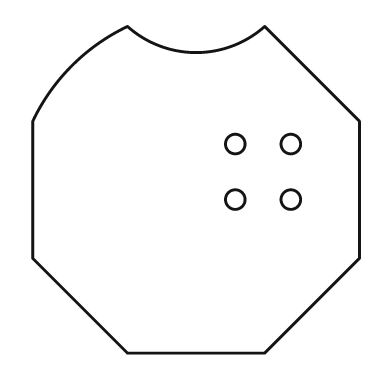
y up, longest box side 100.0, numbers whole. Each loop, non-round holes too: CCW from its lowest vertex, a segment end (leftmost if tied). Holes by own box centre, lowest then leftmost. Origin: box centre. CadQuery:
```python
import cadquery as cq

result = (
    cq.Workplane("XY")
    .moveTo(-21.0, -50.0)
    .lineTo(21.0, -50.0)
    .lineTo(50.0, -21.0)
    .lineTo(50.0, 21.0)
    .lineTo(21.0, 50.0)
    .threePointArc((0.0, 42.0), (-21.0, 50.0))
    .threePointArc((-38.0, 38.0), (-50.0, 21.0))
    .lineTo(-50.0, -21.0)
    .close()
    .moveTo(12.0, -3.0)
    .circle(3.0)
    .moveTo(29.0, -3.0)
    .circle(3.0)
    .moveTo(12.0, 14.0)
    .circle(3.0)
    .moveTo(29.0, 14.0)
    .circle(3.0)
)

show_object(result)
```